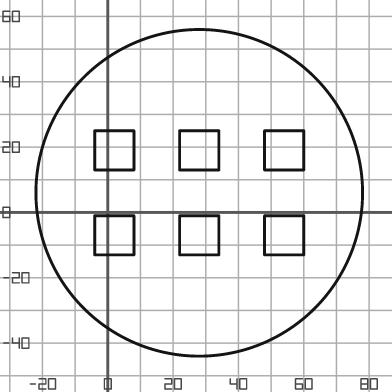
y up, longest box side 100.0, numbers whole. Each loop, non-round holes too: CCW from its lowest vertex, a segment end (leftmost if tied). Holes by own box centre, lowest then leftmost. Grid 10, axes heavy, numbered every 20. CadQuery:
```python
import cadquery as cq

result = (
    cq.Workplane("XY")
    .moveTo(28.0, 6.0)
    .circle(50.0)
    .moveTo(-4.0, -13.0)
    .lineTo(8.0, -13.0)
    .lineTo(8.0, -1.0)
    .lineTo(-4.0, -1.0)
    .close()
    .moveTo(22.0, -13.0)
    .lineTo(34.0, -13.0)
    .lineTo(34.0, -1.0)
    .lineTo(22.0, -1.0)
    .close()
    .moveTo(48.0, -13.0)
    .lineTo(60.0, -13.0)
    .lineTo(60.0, -1.0)
    .lineTo(48.0, -1.0)
    .close()
    .moveTo(-4.0, 13.0)
    .lineTo(8.0, 13.0)
    .lineTo(8.0, 25.0)
    .lineTo(-4.0, 25.0)
    .close()
    .moveTo(22.0, 13.0)
    .lineTo(34.0, 13.0)
    .lineTo(34.0, 25.0)
    .lineTo(22.0, 25.0)
    .close()
    .moveTo(48.0, 13.0)
    .lineTo(60.0, 13.0)
    .lineTo(60.0, 25.0)
    .lineTo(48.0, 25.0)
    .close()
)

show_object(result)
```